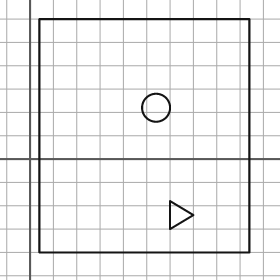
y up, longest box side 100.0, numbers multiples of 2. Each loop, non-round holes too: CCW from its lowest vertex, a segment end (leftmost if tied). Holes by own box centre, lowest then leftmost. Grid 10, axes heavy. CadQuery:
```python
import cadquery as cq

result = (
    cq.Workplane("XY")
    .moveTo(4.0, -40.0)
    .lineTo(94.0, -40.0)
    .lineTo(94.0, 60.0)
    .lineTo(4.0, 60.0)
    .close()
    .moveTo(60.0, -30.0)
    .lineTo(70.0, -24.0)
    .lineTo(60.0, -18.0)
    .close()
    .moveTo(54.0, 22.0)
    .circle(6.0)
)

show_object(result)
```